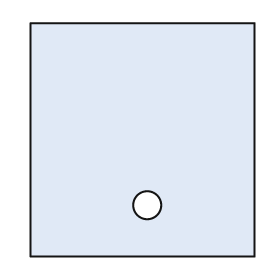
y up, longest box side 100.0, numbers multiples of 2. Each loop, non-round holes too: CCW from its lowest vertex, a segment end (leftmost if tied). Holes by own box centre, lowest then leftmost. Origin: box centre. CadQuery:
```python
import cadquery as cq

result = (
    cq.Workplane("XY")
    .moveTo(-48.0, -50.0)
    .lineTo(48.0, -50.0)
    .lineTo(48.0, 50.0)
    .lineTo(-48.0, 50.0)
    .close()
    .moveTo(2.0, -28.0)
    .circle(6.0)
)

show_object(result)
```